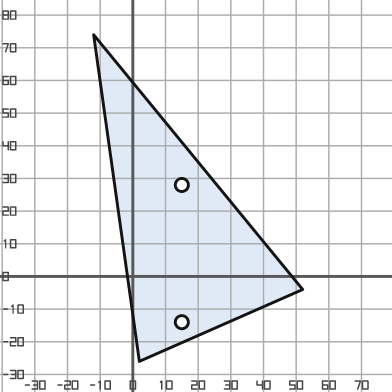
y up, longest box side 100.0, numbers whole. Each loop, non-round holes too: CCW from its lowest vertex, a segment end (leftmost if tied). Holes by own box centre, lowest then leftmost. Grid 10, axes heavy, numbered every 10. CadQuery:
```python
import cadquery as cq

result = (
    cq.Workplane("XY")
    .moveTo(2.0, -26.0)
    .lineTo(52.0, -4.0)
    .lineTo(-12.0, 74.0)
    .close()
    .moveTo(15.0, -14.0)
    .circle(2.0)
    .moveTo(15.0, 28.0)
    .circle(2.0)
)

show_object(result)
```